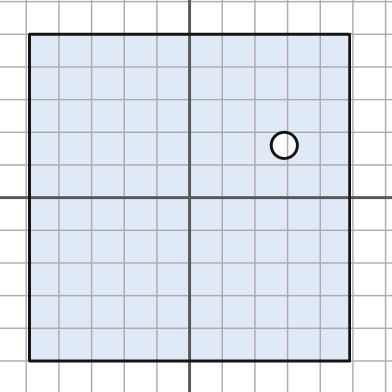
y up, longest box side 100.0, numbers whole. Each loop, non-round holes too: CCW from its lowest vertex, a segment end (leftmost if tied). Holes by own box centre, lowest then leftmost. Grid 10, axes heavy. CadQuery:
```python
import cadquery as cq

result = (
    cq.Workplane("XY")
    .moveTo(-49.0, -50.0)
    .lineTo(49.0, -50.0)
    .lineTo(49.0, 50.0)
    .lineTo(-49.0, 50.0)
    .close()
    .moveTo(29.0, 16.0)
    .circle(4.0)
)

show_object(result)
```